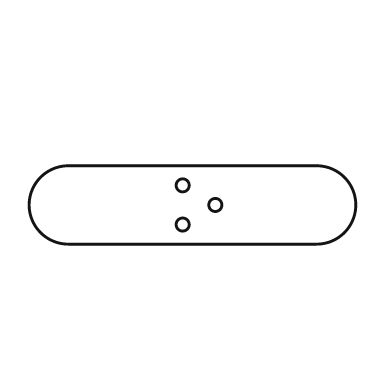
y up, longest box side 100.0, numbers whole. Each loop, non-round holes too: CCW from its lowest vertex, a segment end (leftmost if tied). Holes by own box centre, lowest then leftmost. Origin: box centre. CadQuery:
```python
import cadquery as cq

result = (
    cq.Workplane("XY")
    .moveTo(-38.0, -12.0)
    .lineTo(38.0, -12.0)
    .threePointArc((50.0, 0.0), (38.0, 12.0))
    .lineTo(-38.0, 12.0)
    .threePointArc((-50.0, 0.0), (-38.0, -12.0))
    .close()
    .moveTo(-3.0, -6.0)
    .circle(2.0)
    .moveTo(7.0, 0.0)
    .circle(2.0)
    .moveTo(-3.0, 6.0)
    .circle(2.0)
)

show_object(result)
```